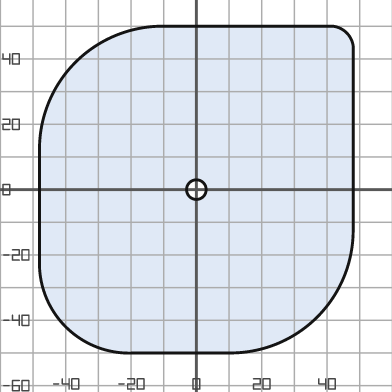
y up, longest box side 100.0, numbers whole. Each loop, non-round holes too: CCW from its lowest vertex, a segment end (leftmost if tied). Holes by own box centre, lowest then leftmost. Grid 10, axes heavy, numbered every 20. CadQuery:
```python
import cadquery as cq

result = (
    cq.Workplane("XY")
    .moveTo(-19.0, -50.0)
    .lineTo(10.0, -50.0)
    .threePointArc((37.0, -39.0), (48.0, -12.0))
    .lineTo(48.0, 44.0)
    .threePointArc((46.0, 48.0), (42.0, 50.0))
    .lineTo(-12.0, 50.0)
    .threePointArc((-37.0, 39.0), (-48.0, 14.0))
    .lineTo(-48.0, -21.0)
    .threePointArc((-40.0, -42.0), (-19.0, -50.0))
    .close()
    .moveTo(0.0, 0.0)
    .circle(3.0)
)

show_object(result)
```